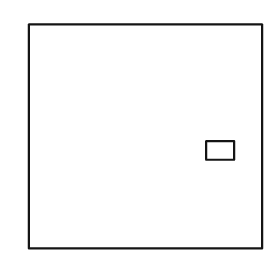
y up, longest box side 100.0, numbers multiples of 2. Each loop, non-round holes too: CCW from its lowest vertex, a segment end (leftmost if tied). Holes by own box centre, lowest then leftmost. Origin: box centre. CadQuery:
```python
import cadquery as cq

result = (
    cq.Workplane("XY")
    .moveTo(-50.0, -48.0)
    .lineTo(50.0, -48.0)
    .lineTo(50.0, 48.0)
    .lineTo(-50.0, 48.0)
    .close()
    .moveTo(26.0, -10.0)
    .lineTo(38.0, -10.0)
    .lineTo(38.0, -2.0)
    .lineTo(26.0, -2.0)
    .close()
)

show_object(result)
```